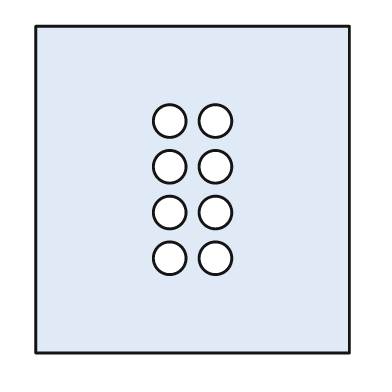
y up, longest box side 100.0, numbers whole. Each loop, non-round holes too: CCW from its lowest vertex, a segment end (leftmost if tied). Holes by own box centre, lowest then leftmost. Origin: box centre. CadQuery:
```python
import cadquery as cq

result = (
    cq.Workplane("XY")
    .moveTo(-48.0, -50.0)
    .lineTo(48.0, -50.0)
    .lineTo(48.0, 50.0)
    .lineTo(-48.0, 50.0)
    .close()
    .moveTo(-7.0, -21.0)
    .circle(5.0)
    .moveTo(7.0, -21.0)
    .circle(5.0)
    .moveTo(-7.0, -7.0)
    .circle(5.0)
    .moveTo(7.0, -7.0)
    .circle(5.0)
    .moveTo(-7.0, 7.0)
    .circle(5.0)
    .moveTo(7.0, 7.0)
    .circle(5.0)
    .moveTo(-7.0, 21.0)
    .circle(5.0)
    .moveTo(7.0, 21.0)
    .circle(5.0)
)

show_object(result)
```